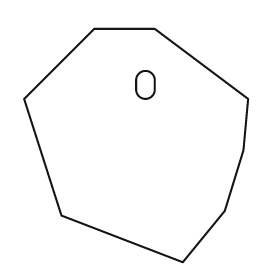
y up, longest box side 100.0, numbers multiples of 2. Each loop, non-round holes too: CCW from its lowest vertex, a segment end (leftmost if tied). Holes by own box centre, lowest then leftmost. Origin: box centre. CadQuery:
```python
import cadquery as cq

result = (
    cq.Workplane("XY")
    .moveTo(20.0, -50.0)
    .lineTo(38.0, -28.0)
    .lineTo(46.0, -2.0)
    .lineTo(48.0, 20.0)
    .lineTo(8.0, 50.0)
    .lineTo(-18.0, 50.0)
    .lineTo(-48.0, 20.0)
    .lineTo(-32.0, -30.0)
    .close()
    .moveTo(0.0, 24.0)
    .threePointArc((4.0, 20.0), (8.0, 24.0))
    .lineTo(8.0, 28.0)
    .threePointArc((4.0, 32.0), (0.0, 28.0))
    .close()
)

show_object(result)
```